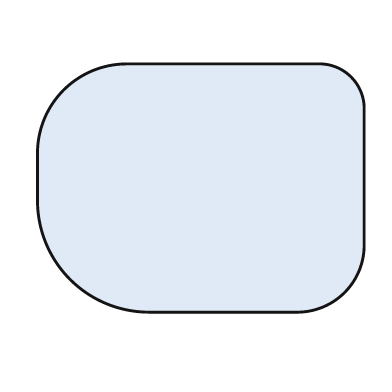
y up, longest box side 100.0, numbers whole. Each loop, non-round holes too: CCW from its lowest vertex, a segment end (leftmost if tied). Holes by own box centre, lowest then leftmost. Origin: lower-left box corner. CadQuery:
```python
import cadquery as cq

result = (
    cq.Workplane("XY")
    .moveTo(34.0, 0.0)
    .lineTo(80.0, 0.0)
    .threePointArc((94.0, 6.0), (100.0, 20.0))
    .lineTo(100.0, 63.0)
    .threePointArc((96.0, 72.0), (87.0, 76.0))
    .lineTo(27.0, 76.0)
    .threePointArc((8.0, 68.0), (0.0, 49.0))
    .lineTo(0.0, 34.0)
    .threePointArc((10.0, 10.0), (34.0, 0.0))
    .close()
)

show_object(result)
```